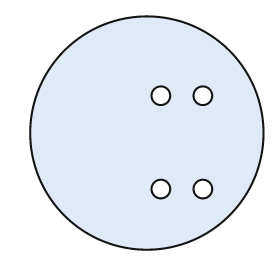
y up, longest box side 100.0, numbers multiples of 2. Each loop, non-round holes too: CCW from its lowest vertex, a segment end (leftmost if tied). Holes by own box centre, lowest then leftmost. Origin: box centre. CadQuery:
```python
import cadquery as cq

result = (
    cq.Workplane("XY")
    .moveTo(0.0, 0.0)
    .circle(50.0)
    .moveTo(6.0, -24.0)
    .circle(4.0)
    .moveTo(24.0, -24.0)
    .circle(4.0)
    .moveTo(6.0, 16.0)
    .circle(4.0)
    .moveTo(24.0, 16.0)
    .circle(4.0)
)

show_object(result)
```